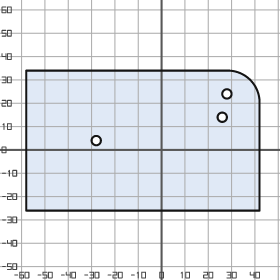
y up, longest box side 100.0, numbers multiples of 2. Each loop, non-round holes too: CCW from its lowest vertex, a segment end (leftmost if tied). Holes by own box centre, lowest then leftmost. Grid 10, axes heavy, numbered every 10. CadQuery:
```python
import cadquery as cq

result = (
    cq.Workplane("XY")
    .moveTo(-58.0, -26.0)
    .lineTo(42.0, -26.0)
    .lineTo(42.0, 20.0)
    .threePointArc((38.0, 30.0), (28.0, 34.0))
    .lineTo(-58.0, 34.0)
    .close()
    .moveTo(-28.0, 4.0)
    .circle(2.0)
    .moveTo(26.0, 14.0)
    .circle(2.0)
    .moveTo(28.0, 24.0)
    .circle(2.0)
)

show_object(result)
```